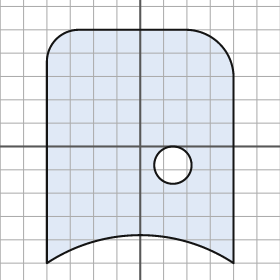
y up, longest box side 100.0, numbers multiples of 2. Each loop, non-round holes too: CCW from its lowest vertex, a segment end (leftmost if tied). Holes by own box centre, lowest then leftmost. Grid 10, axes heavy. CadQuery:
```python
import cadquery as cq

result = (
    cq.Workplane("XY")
    .moveTo(-40.0, -50.0)
    .threePointArc((0.0, -38.0), (40.0, -50.0))
    .lineTo(40.0, 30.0)
    .threePointArc((34.0, 44.0), (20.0, 50.0))
    .lineTo(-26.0, 50.0)
    .threePointArc((-36.0, 46.0), (-40.0, 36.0))
    .close()
    .moveTo(14.0, -8.0)
    .circle(8.0)
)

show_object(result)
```